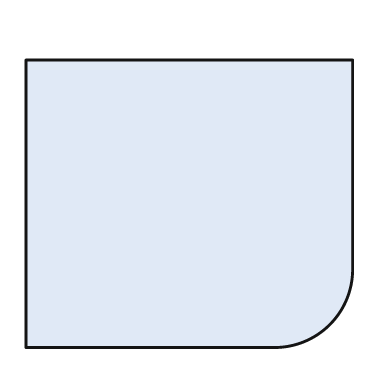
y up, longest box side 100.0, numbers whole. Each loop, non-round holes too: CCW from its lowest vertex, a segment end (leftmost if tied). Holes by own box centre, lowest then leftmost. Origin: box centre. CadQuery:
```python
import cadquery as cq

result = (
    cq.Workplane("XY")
    .moveTo(-50.0, -44.0)
    .lineTo(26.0, -44.0)
    .threePointArc((43.0, -37.0), (50.0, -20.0))
    .lineTo(50.0, 44.0)
    .lineTo(-50.0, 44.0)
    .close()
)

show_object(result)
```